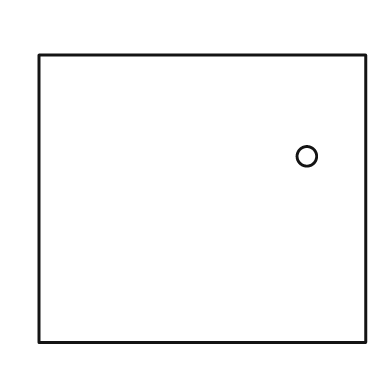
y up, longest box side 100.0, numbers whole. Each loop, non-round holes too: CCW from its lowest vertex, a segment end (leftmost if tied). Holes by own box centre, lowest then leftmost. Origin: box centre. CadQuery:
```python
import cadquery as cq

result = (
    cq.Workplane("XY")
    .moveTo(-50.0, -44.0)
    .lineTo(50.0, -44.0)
    .lineTo(50.0, 44.0)
    .lineTo(-50.0, 44.0)
    .close()
    .moveTo(32.0, 13.0)
    .circle(3.0)
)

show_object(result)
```